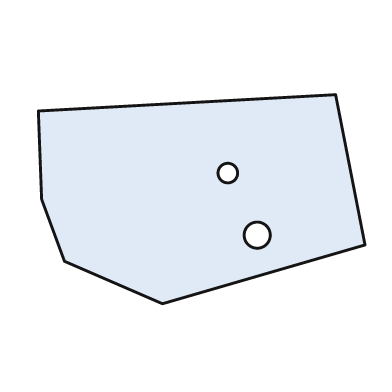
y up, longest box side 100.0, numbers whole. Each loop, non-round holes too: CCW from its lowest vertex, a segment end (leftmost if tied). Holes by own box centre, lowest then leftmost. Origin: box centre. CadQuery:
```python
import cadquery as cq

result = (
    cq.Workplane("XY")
    .moveTo(-12.0, -32.0)
    .lineTo(50.0, -14.0)
    .lineTo(41.0, 32.0)
    .lineTo(-50.0, 27.0)
    .lineTo(-49.0, 0.0)
    .lineTo(-42.0, -19.0)
    .close()
    .moveTo(17.0, -11.0)
    .circle(4.0)
    .moveTo(8.0, 8.0)
    .circle(3.0)
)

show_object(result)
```